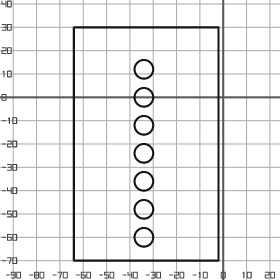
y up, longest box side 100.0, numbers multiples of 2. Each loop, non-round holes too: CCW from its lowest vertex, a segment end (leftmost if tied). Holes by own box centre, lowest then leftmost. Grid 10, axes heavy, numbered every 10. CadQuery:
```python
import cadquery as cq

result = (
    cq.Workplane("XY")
    .moveTo(-64.0, -70.0)
    .lineTo(-2.0, -70.0)
    .lineTo(-2.0, 30.0)
    .lineTo(-64.0, 30.0)
    .close()
    .moveTo(-34.0, -60.0)
    .circle(4.0)
    .moveTo(-34.0, -48.0)
    .circle(4.0)
    .moveTo(-34.0, -36.0)
    .circle(4.0)
    .moveTo(-34.0, -24.0)
    .circle(4.0)
    .moveTo(-34.0, -12.0)
    .circle(4.0)
    .moveTo(-34.0, 0.0)
    .circle(4.0)
    .moveTo(-34.0, 12.0)
    .circle(4.0)
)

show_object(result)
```